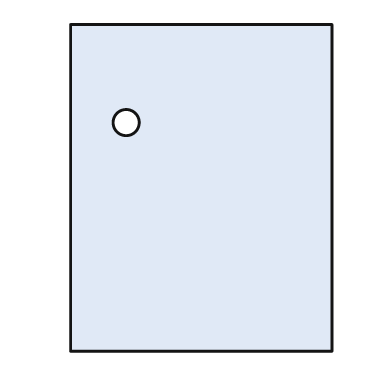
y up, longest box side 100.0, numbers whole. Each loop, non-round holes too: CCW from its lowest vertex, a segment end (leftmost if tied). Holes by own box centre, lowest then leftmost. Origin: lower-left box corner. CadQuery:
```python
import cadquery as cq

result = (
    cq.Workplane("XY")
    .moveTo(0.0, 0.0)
    .lineTo(80.0, 0.0)
    .lineTo(80.0, 100.0)
    .lineTo(0.0, 100.0)
    .close()
    .moveTo(17.0, 70.0)
    .circle(4.0)
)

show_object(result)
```